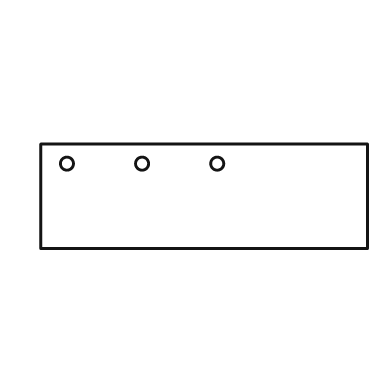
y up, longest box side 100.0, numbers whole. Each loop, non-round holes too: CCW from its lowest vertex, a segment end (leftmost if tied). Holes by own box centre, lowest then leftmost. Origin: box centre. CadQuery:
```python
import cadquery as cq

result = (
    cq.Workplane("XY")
    .moveTo(-50.0, -16.0)
    .lineTo(50.0, -16.0)
    .lineTo(50.0, 16.0)
    .lineTo(-50.0, 16.0)
    .close()
    .moveTo(-42.0, 10.0)
    .circle(2.0)
    .moveTo(-19.0, 10.0)
    .circle(2.0)
    .moveTo(4.0, 10.0)
    .circle(2.0)
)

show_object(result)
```